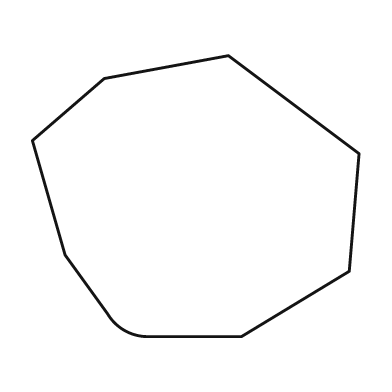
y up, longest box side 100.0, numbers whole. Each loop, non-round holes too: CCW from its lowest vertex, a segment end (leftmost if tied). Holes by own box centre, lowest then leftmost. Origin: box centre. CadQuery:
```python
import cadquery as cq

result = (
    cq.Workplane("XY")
    .moveTo(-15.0, -43.0)
    .lineTo(14.0, -43.0)
    .lineTo(47.0, -23.0)
    .lineTo(50.0, 13.0)
    .lineTo(10.0, 43.0)
    .lineTo(-28.0, 36.0)
    .lineTo(-50.0, 17.0)
    .lineTo(-40.0, -18.0)
    .lineTo(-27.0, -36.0)
    .threePointArc((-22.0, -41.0), (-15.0, -43.0))
    .close()
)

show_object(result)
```